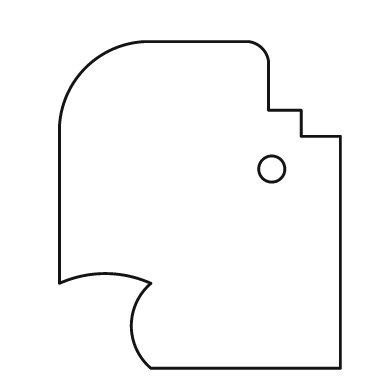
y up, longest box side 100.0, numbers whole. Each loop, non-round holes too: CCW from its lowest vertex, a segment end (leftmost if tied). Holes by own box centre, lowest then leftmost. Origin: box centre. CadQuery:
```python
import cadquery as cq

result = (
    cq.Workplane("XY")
    .moveTo(-15.0, -50.0)
    .lineTo(43.0, -50.0)
    .lineTo(43.0, 21.0)
    .lineTo(31.0, 21.0)
    .lineTo(31.0, 29.0)
    .lineTo(21.0, 29.0)
    .lineTo(21.0, 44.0)
    .threePointArc((19.0, 48.0), (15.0, 50.0))
    .lineTo(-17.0, 50.0)
    .threePointArc((-35.0, 42.0), (-43.0, 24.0))
    .lineTo(-43.0, -24.0)
    .threePointArc((-29.0, -21.0), (-15.0, -24.0))
    .threePointArc((-21.0, -37.0), (-15.0, -50.0))
    .close()
    .moveTo(22.0, 11.0)
    .circle(4.0)
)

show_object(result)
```